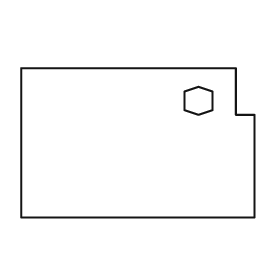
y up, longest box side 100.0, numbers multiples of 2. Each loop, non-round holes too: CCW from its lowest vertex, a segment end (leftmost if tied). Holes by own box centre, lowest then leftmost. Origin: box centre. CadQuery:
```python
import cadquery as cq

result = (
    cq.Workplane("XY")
    .moveTo(-50.0, -32.0)
    .lineTo(50.0, -32.0)
    .lineTo(50.0, 12.0)
    .lineTo(42.0, 12.0)
    .lineTo(42.0, 32.0)
    .lineTo(-50.0, 32.0)
    .close()
    .moveTo(26.0, 12.0)
    .lineTo(32.0, 14.0)
    .lineTo(32.0, 22.0)
    .lineTo(26.0, 24.0)
    .lineTo(20.0, 22.0)
    .lineTo(20.0, 14.0)
    .close()
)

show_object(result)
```